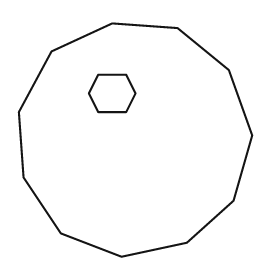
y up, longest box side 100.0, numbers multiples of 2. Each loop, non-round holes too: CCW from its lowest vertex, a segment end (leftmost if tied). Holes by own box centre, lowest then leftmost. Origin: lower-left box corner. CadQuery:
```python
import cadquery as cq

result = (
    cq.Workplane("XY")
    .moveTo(44.0, 0.0)
    .lineTo(72.0, 6.0)
    .lineTo(92.0, 24.0)
    .lineTo(100.0, 52.0)
    .lineTo(90.0, 80.0)
    .lineTo(68.0, 98.0)
    .lineTo(40.0, 100.0)
    .lineTo(14.0, 88.0)
    .lineTo(0.0, 62.0)
    .lineTo(2.0, 34.0)
    .lineTo(18.0, 10.0)
    .close()
    .moveTo(34.0, 62.0)
    .lineTo(46.0, 62.0)
    .lineTo(50.0, 70.0)
    .lineTo(46.0, 78.0)
    .lineTo(34.0, 78.0)
    .lineTo(30.0, 70.0)
    .close()
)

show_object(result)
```